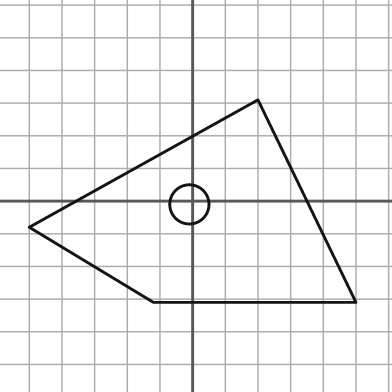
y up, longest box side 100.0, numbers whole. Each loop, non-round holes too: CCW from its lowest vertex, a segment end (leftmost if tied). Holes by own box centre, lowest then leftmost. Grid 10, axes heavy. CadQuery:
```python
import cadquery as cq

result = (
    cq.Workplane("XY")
    .moveTo(-12.0, -31.0)
    .lineTo(50.0, -31.0)
    .lineTo(20.0, 31.0)
    .lineTo(-50.0, -8.0)
    .close()
    .moveTo(-1.0, -1.0)
    .circle(6.0)
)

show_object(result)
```